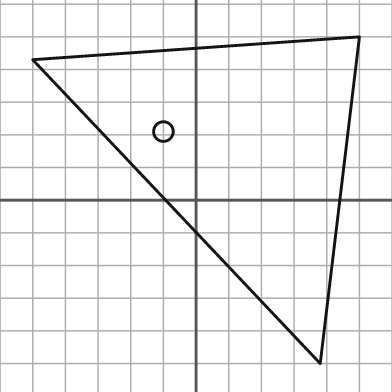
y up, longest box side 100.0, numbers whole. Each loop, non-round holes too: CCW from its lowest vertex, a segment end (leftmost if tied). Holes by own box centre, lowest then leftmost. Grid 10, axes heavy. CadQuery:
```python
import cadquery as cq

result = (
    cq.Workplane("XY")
    .moveTo(38.0, -50.0)
    .lineTo(50.0, 50.0)
    .lineTo(-50.0, 43.0)
    .close()
    .moveTo(-10.0, 21.0)
    .circle(3.0)
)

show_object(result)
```